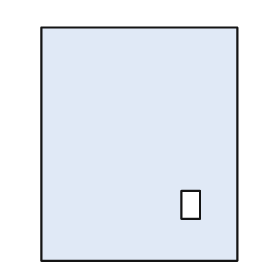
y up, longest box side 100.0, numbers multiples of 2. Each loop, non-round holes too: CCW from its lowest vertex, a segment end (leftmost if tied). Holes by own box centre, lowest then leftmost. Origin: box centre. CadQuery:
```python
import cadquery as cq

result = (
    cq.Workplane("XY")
    .moveTo(-42.0, -50.0)
    .lineTo(42.0, -50.0)
    .lineTo(42.0, 50.0)
    .lineTo(-42.0, 50.0)
    .close()
    .moveTo(18.0, -32.0)
    .lineTo(26.0, -32.0)
    .lineTo(26.0, -20.0)
    .lineTo(18.0, -20.0)
    .close()
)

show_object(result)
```